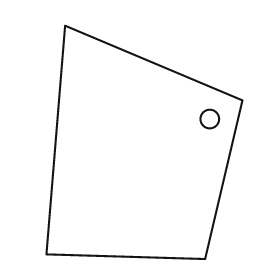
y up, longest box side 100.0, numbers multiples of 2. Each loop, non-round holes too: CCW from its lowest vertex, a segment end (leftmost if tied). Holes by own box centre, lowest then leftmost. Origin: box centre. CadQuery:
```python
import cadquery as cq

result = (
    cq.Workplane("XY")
    .moveTo(26.0, -50.0)
    .lineTo(42.0, 18.0)
    .lineTo(-34.0, 50.0)
    .lineTo(-42.0, -48.0)
    .close()
    .moveTo(28.0, 10.0)
    .circle(4.0)
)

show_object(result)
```